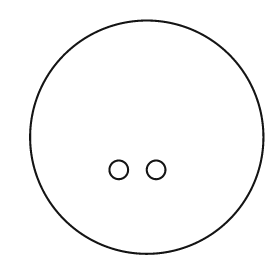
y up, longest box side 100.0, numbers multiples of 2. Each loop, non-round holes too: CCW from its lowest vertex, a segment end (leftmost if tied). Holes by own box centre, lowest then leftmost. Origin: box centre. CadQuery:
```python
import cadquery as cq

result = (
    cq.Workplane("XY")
    .moveTo(0.0, 0.0)
    .circle(50.0)
    .moveTo(-12.0, -14.0)
    .circle(4.0)
    .moveTo(4.0, -14.0)
    .circle(4.0)
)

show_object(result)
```